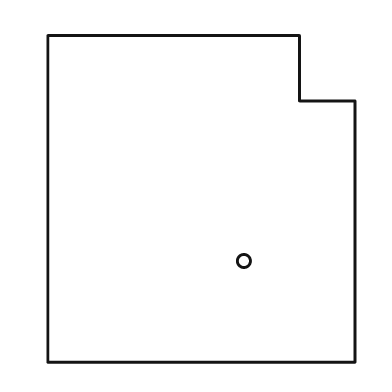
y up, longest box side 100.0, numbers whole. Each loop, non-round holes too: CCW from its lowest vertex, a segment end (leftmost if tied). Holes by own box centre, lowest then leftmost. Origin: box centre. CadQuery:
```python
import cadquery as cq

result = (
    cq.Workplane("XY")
    .moveTo(-47.0, -50.0)
    .lineTo(47.0, -50.0)
    .lineTo(47.0, 30.0)
    .lineTo(30.0, 30.0)
    .lineTo(30.0, 50.0)
    .lineTo(-47.0, 50.0)
    .close()
    .moveTo(13.0, -19.0)
    .circle(2.0)
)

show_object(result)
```